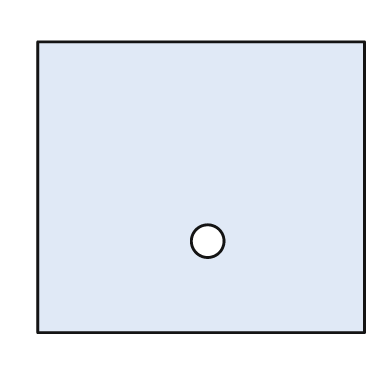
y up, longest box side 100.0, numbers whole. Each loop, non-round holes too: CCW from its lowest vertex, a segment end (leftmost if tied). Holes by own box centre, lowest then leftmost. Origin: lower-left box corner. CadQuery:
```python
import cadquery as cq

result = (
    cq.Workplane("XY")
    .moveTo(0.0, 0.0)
    .lineTo(100.0, 0.0)
    .lineTo(100.0, 89.0)
    .lineTo(0.0, 89.0)
    .close()
    .moveTo(52.0, 28.0)
    .circle(5.0)
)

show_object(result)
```